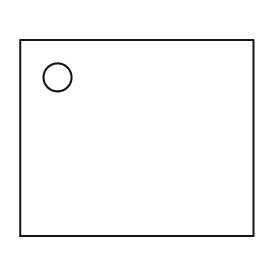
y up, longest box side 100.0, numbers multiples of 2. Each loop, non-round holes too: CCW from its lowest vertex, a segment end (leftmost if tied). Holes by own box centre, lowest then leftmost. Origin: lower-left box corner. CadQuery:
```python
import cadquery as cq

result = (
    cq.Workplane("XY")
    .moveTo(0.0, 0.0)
    .lineTo(100.0, 0.0)
    .lineTo(100.0, 84.0)
    .lineTo(0.0, 84.0)
    .close()
    .moveTo(16.0, 68.0)
    .circle(6.0)
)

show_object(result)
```